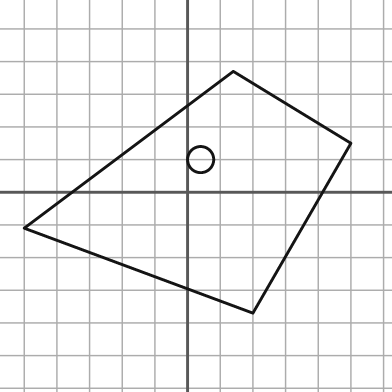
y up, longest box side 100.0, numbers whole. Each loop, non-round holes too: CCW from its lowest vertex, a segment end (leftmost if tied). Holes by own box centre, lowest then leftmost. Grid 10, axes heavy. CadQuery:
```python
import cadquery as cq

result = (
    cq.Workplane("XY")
    .moveTo(20.0, -37.0)
    .lineTo(50.0, 15.0)
    .lineTo(14.0, 37.0)
    .lineTo(-50.0, -11.0)
    .close()
    .moveTo(4.0, 10.0)
    .circle(4.0)
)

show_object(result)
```